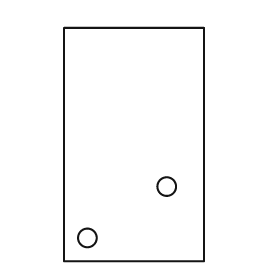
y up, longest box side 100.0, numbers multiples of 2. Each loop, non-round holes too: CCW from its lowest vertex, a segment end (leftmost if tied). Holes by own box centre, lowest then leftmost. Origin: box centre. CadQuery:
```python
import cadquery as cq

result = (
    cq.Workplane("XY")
    .moveTo(-30.0, -50.0)
    .lineTo(30.0, -50.0)
    .lineTo(30.0, 50.0)
    .lineTo(-30.0, 50.0)
    .close()
    .moveTo(-20.0, -40.0)
    .circle(4.0)
    .moveTo(14.0, -18.0)
    .circle(4.0)
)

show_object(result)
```